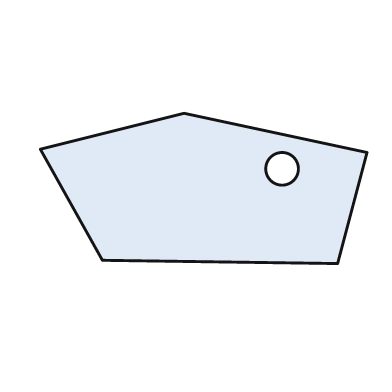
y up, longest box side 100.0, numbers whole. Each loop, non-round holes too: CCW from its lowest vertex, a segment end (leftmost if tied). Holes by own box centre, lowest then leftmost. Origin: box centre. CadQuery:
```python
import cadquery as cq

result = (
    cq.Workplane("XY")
    .moveTo(41.0, -23.0)
    .lineTo(50.0, 11.0)
    .lineTo(-6.0, 23.0)
    .lineTo(-50.0, 12.0)
    .lineTo(-31.0, -22.0)
    .close()
    .moveTo(24.0, 6.0)
    .circle(5.0)
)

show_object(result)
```